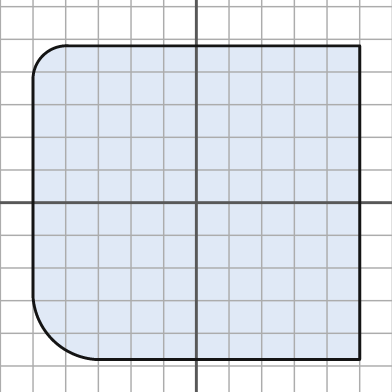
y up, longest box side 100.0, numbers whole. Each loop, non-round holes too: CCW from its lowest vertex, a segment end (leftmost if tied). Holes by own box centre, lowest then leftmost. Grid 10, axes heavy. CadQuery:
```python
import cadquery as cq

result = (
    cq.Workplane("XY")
    .moveTo(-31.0, -48.0)
    .lineTo(50.0, -48.0)
    .lineTo(50.0, 48.0)
    .lineTo(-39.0, 48.0)
    .threePointArc((-47.0, 45.0), (-50.0, 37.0))
    .lineTo(-50.0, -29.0)
    .threePointArc((-44.0, -42.0), (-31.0, -48.0))
    .close()
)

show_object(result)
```